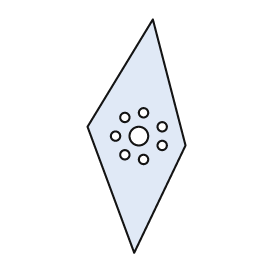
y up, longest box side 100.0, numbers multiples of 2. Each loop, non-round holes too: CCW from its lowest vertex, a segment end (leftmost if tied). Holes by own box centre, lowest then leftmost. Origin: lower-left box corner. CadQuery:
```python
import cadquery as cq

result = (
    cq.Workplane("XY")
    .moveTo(20.0, 0.0)
    .lineTo(42.0, 46.0)
    .lineTo(28.0, 100.0)
    .lineTo(0.0, 54.0)
    .close()
    .moveTo(24.0, 40.0)
    .circle(2.0)
    .moveTo(16.0, 42.0)
    .circle(2.0)
    .moveTo(32.0, 46.0)
    .circle(2.0)
    .moveTo(12.0, 50.0)
    .circle(2.0)
    .moveTo(22.0, 50.0)
    .circle(4.0)
    .moveTo(32.0, 54.0)
    .circle(2.0)
    .moveTo(16.0, 58.0)
    .circle(2.0)
    .moveTo(24.0, 60.0)
    .circle(2.0)
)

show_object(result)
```